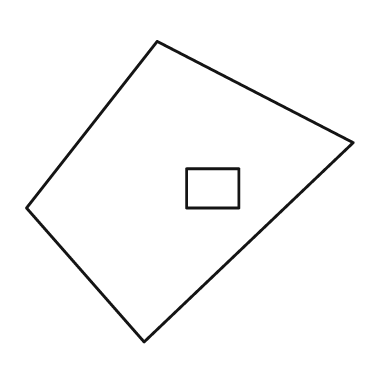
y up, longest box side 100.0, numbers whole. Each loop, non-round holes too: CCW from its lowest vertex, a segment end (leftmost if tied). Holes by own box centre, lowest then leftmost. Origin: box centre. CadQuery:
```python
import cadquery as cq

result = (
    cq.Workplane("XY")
    .moveTo(-14.0, -46.0)
    .lineTo(50.0, 15.0)
    .lineTo(-10.0, 46.0)
    .lineTo(-50.0, -5.0)
    .close()
    .moveTo(-1.0, -5.0)
    .lineTo(15.0, -5.0)
    .lineTo(15.0, 7.0)
    .lineTo(-1.0, 7.0)
    .close()
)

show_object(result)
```